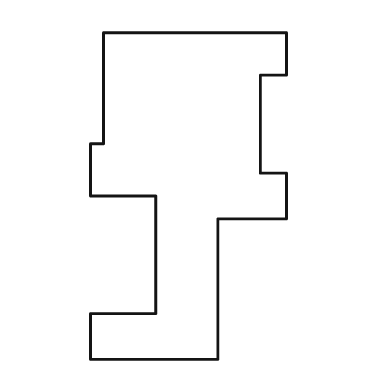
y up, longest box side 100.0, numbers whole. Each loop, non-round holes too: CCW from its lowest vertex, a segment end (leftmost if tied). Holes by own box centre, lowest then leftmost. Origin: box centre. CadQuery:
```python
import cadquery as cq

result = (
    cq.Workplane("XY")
    .moveTo(-30.0, -50.0)
    .lineTo(9.0, -50.0)
    .lineTo(9.0, -7.0)
    .lineTo(30.0, -7.0)
    .lineTo(30.0, 7.0)
    .lineTo(22.0, 7.0)
    .lineTo(22.0, 37.0)
    .lineTo(30.0, 37.0)
    .lineTo(30.0, 50.0)
    .lineTo(-26.0, 50.0)
    .lineTo(-26.0, 16.0)
    .lineTo(-30.0, 16.0)
    .lineTo(-30.0, 0.0)
    .lineTo(-10.0, 0.0)
    .lineTo(-10.0, -36.0)
    .lineTo(-30.0, -36.0)
    .close()
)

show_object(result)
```